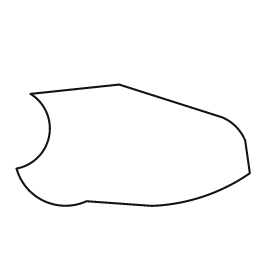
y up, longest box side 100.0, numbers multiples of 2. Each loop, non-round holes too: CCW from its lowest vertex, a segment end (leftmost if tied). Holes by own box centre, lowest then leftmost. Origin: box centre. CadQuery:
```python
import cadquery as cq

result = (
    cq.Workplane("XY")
    .moveTo(8.0, -26.0)
    .threePointArc((30.0, -22.0), (50.0, -12.0))
    .lineTo(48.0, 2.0)
    .threePointArc((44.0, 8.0), (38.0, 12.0))
    .lineTo(-6.0, 26.0)
    .lineTo(-44.0, 22.0)
    .threePointArc((-36.0, 4.0), (-50.0, -10.0))
    .threePointArc((-38.0, -24.0), (-20.0, -24.0))
    .close()
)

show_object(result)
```